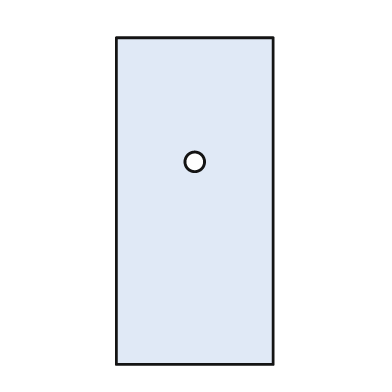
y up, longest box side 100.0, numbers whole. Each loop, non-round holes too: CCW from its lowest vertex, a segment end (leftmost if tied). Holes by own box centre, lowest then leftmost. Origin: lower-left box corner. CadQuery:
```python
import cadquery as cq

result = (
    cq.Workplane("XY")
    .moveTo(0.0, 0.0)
    .lineTo(48.0, 0.0)
    .lineTo(48.0, 100.0)
    .lineTo(0.0, 100.0)
    .close()
    .moveTo(24.0, 62.0)
    .circle(3.0)
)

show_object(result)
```